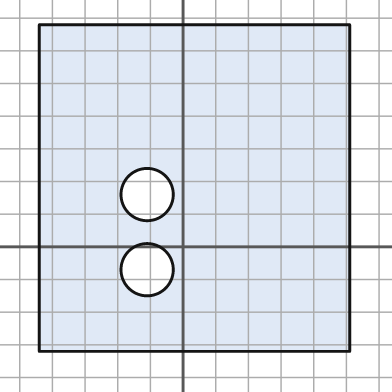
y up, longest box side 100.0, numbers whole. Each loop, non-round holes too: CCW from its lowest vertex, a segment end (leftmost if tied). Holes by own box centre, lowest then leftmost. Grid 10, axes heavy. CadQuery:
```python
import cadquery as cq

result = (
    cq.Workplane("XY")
    .moveTo(-44.0, -32.0)
    .lineTo(51.0, -32.0)
    .lineTo(51.0, 68.0)
    .lineTo(-44.0, 68.0)
    .close()
    .moveTo(-11.0, -7.0)
    .circle(8.0)
    .moveTo(-11.0, 16.0)
    .circle(8.0)
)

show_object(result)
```